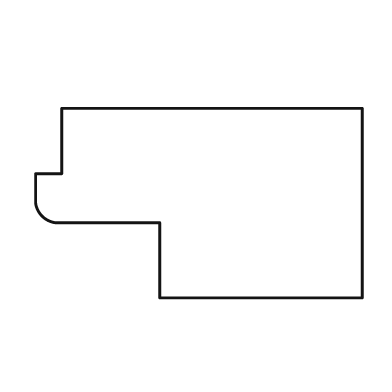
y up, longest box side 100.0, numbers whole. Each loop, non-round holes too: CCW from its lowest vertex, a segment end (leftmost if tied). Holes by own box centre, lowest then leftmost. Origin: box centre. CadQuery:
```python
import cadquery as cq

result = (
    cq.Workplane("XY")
    .moveTo(-12.0, -29.0)
    .lineTo(50.0, -29.0)
    .lineTo(50.0, 29.0)
    .lineTo(-42.0, 29.0)
    .lineTo(-42.0, 9.0)
    .lineTo(-50.0, 9.0)
    .lineTo(-50.0, 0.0)
    .threePointArc((-48.0, -4.0), (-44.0, -6.0))
    .lineTo(-12.0, -6.0)
    .close()
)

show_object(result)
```